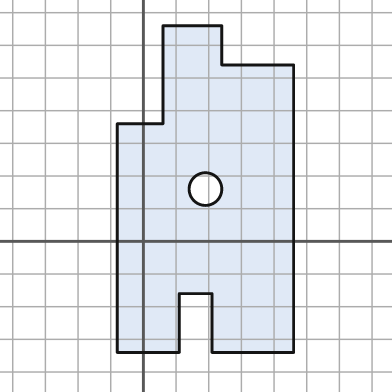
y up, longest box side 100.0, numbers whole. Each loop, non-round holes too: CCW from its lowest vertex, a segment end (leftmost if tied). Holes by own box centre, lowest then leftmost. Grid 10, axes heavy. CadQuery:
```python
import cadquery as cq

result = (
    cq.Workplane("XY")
    .moveTo(-8.0, -34.0)
    .lineTo(11.0, -34.0)
    .lineTo(11.0, -16.0)
    .lineTo(21.0, -16.0)
    .lineTo(21.0, -34.0)
    .lineTo(46.0, -34.0)
    .lineTo(46.0, 54.0)
    .lineTo(24.0, 54.0)
    .lineTo(24.0, 66.0)
    .lineTo(6.0, 66.0)
    .lineTo(6.0, 36.0)
    .lineTo(-8.0, 36.0)
    .close()
    .moveTo(19.0, 16.0)
    .circle(5.0)
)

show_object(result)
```